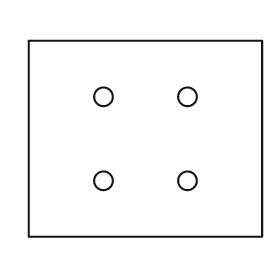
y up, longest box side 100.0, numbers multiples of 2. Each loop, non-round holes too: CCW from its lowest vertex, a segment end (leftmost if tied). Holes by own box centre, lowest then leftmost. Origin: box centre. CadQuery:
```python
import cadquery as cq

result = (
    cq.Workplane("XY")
    .moveTo(-50.0, -42.0)
    .lineTo(50.0, -42.0)
    .lineTo(50.0, 42.0)
    .lineTo(-50.0, 42.0)
    .close()
    .moveTo(-18.0, -18.0)
    .circle(4.0)
    .moveTo(18.0, -18.0)
    .circle(4.0)
    .moveTo(-18.0, 18.0)
    .circle(4.0)
    .moveTo(18.0, 18.0)
    .circle(4.0)
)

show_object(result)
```